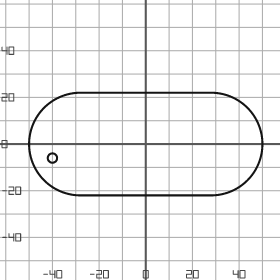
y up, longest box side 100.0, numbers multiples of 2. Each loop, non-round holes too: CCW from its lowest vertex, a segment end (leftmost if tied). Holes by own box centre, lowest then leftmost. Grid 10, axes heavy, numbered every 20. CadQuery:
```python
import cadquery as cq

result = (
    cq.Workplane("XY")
    .moveTo(-28.0, -22.0)
    .lineTo(28.0, -22.0)
    .threePointArc((50.0, 0.0), (28.0, 22.0))
    .lineTo(-28.0, 22.0)
    .threePointArc((-50.0, 0.0), (-28.0, -22.0))
    .close()
    .moveTo(-40.0, -6.0)
    .circle(2.0)
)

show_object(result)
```